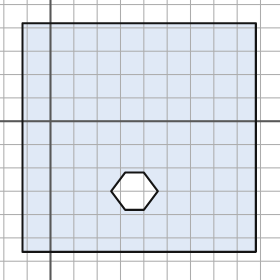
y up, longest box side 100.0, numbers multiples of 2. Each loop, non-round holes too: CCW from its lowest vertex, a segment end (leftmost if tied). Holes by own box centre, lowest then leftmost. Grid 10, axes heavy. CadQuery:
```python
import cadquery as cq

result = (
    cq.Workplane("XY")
    .moveTo(-12.0, -56.0)
    .lineTo(88.0, -56.0)
    .lineTo(88.0, 42.0)
    .lineTo(-12.0, 42.0)
    .close()
    .moveTo(32.0, -38.0)
    .lineTo(40.0, -38.0)
    .lineTo(46.0, -30.0)
    .lineTo(40.0, -22.0)
    .lineTo(32.0, -22.0)
    .lineTo(26.0, -30.0)
    .close()
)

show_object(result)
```